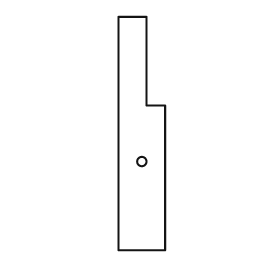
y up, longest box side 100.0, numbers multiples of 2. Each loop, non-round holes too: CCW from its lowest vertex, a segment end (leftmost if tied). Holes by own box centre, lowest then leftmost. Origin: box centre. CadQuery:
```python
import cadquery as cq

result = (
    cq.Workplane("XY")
    .moveTo(-10.0, -50.0)
    .lineTo(10.0, -50.0)
    .lineTo(10.0, 12.0)
    .lineTo(2.0, 12.0)
    .lineTo(2.0, 50.0)
    .lineTo(-10.0, 50.0)
    .close()
    .moveTo(0.0, -12.0)
    .circle(2.0)
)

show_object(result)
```